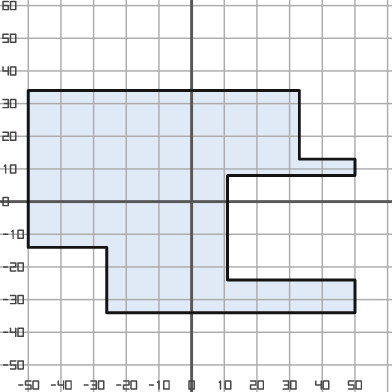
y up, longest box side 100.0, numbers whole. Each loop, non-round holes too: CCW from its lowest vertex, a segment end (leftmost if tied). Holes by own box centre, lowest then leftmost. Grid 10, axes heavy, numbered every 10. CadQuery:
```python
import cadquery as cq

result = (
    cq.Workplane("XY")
    .moveTo(-26.0, -34.0)
    .lineTo(50.0, -34.0)
    .lineTo(50.0, -24.0)
    .lineTo(11.0, -24.0)
    .lineTo(11.0, 8.0)
    .lineTo(50.0, 8.0)
    .lineTo(50.0, 13.0)
    .lineTo(33.0, 13.0)
    .lineTo(33.0, 34.0)
    .lineTo(-50.0, 34.0)
    .lineTo(-50.0, -14.0)
    .lineTo(-26.0, -14.0)
    .close()
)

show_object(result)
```